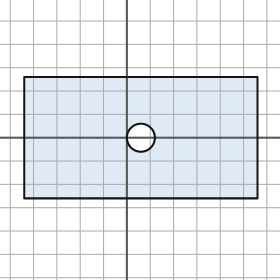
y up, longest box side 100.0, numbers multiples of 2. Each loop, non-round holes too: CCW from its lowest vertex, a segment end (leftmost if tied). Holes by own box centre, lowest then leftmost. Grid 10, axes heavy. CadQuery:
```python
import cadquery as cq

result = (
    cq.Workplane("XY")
    .moveTo(-44.0, -26.0)
    .lineTo(56.0, -26.0)
    .lineTo(56.0, 26.0)
    .lineTo(-44.0, 26.0)
    .close()
    .moveTo(6.0, 0.0)
    .circle(6.0)
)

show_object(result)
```